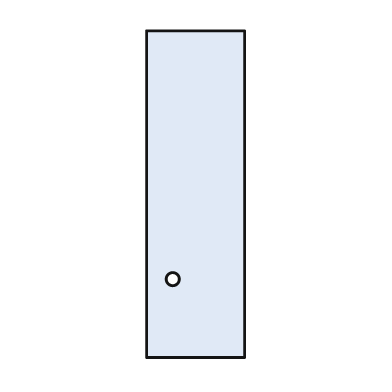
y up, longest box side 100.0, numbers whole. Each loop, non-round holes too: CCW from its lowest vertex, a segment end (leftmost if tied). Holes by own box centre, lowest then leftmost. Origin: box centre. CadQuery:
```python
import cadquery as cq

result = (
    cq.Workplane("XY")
    .moveTo(-15.0, -50.0)
    .lineTo(15.0, -50.0)
    .lineTo(15.0, 50.0)
    .lineTo(-15.0, 50.0)
    .close()
    .moveTo(-7.0, -26.0)
    .circle(2.0)
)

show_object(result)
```